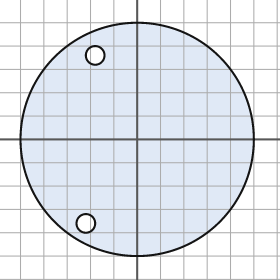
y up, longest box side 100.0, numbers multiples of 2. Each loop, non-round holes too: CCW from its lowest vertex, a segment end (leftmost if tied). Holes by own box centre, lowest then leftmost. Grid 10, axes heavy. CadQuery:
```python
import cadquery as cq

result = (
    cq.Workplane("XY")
    .moveTo(0.0, 0.0)
    .circle(50.0)
    .moveTo(-22.0, -36.0)
    .circle(4.0)
    .moveTo(-18.0, 36.0)
    .circle(4.0)
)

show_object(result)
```